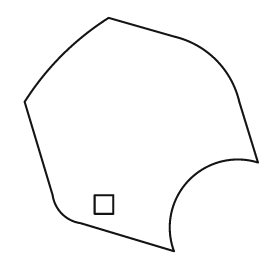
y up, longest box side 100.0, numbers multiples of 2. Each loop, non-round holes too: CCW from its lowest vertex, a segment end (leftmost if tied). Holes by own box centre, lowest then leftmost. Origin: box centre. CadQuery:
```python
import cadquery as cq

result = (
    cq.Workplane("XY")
    .moveTo(14.0, -50.0)
    .threePointArc((20.0, -20.0), (50.0, -12.0))
    .lineTo(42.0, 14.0)
    .threePointArc((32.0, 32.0), (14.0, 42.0))
    .lineTo(-14.0, 50.0)
    .threePointArc((-34.0, 34.0), (-50.0, 14.0))
    .lineTo(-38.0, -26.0)
    .threePointArc((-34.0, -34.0), (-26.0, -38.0))
    .close()
    .moveTo(-20.0, -34.0)
    .lineTo(-12.0, -34.0)
    .lineTo(-12.0, -26.0)
    .lineTo(-20.0, -26.0)
    .close()
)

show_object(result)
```